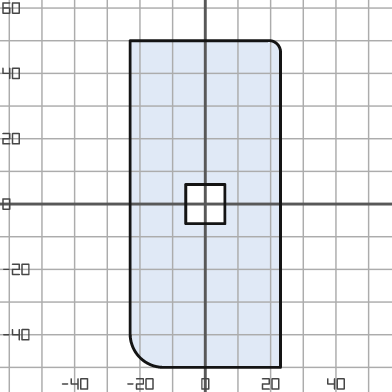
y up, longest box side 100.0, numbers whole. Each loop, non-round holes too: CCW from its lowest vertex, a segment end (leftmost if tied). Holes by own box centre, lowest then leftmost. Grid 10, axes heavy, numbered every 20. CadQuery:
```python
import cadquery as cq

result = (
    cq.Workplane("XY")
    .moveTo(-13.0, -50.0)
    .lineTo(23.0, -50.0)
    .lineTo(23.0, 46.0)
    .threePointArc((22.0, 49.0), (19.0, 50.0))
    .lineTo(-23.0, 50.0)
    .lineTo(-23.0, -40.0)
    .threePointArc((-20.0, -47.0), (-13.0, -50.0))
    .close()
    .moveTo(-6.0, -6.0)
    .lineTo(6.0, -6.0)
    .lineTo(6.0, 6.0)
    .lineTo(-6.0, 6.0)
    .close()
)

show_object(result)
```